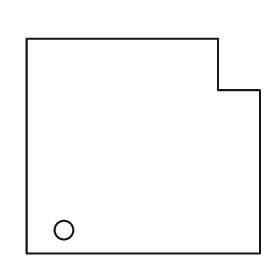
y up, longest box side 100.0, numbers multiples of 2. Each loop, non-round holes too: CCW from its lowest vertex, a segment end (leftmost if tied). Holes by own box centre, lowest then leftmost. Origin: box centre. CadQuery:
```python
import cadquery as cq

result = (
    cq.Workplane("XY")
    .moveTo(-50.0, -46.0)
    .lineTo(50.0, -46.0)
    .lineTo(50.0, 24.0)
    .lineTo(32.0, 24.0)
    .lineTo(32.0, 46.0)
    .lineTo(-50.0, 46.0)
    .close()
    .moveTo(-34.0, -36.0)
    .circle(4.0)
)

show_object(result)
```